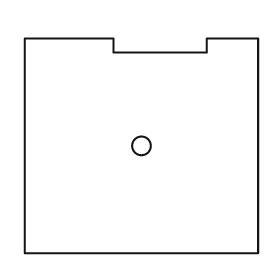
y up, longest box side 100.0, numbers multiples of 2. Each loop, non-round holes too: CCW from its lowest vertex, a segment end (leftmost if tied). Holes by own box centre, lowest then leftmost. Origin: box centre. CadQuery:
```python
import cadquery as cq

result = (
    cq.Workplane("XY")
    .moveTo(-50.0, -46.0)
    .lineTo(50.0, -46.0)
    .lineTo(50.0, 46.0)
    .lineTo(28.0, 46.0)
    .lineTo(28.0, 40.0)
    .lineTo(-12.0, 40.0)
    .lineTo(-12.0, 46.0)
    .lineTo(-50.0, 46.0)
    .close()
    .moveTo(0.0, 0.0)
    .circle(4.0)
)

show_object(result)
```